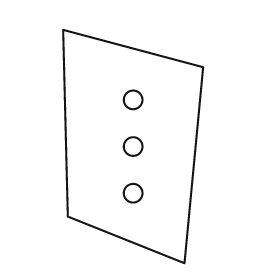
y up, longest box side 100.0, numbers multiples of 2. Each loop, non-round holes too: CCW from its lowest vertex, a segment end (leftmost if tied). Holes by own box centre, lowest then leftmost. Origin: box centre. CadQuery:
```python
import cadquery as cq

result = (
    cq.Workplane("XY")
    .moveTo(22.0, -50.0)
    .lineTo(30.0, 34.0)
    .lineTo(-30.0, 50.0)
    .lineTo(-28.0, -30.0)
    .close()
    .moveTo(0.0, -20.0)
    .circle(4.0)
    .moveTo(0.0, 0.0)
    .circle(4.0)
    .moveTo(0.0, 20.0)
    .circle(4.0)
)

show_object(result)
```